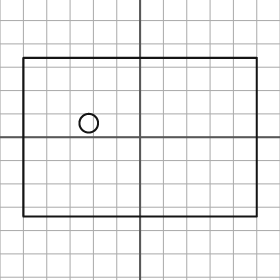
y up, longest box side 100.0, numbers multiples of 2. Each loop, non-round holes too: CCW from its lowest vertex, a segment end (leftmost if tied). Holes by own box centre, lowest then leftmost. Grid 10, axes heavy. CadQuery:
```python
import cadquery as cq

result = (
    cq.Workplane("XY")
    .moveTo(-50.0, -34.0)
    .lineTo(50.0, -34.0)
    .lineTo(50.0, 34.0)
    .lineTo(-50.0, 34.0)
    .close()
    .moveTo(-22.0, 6.0)
    .circle(4.0)
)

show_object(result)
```